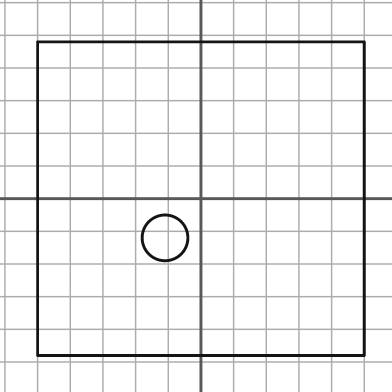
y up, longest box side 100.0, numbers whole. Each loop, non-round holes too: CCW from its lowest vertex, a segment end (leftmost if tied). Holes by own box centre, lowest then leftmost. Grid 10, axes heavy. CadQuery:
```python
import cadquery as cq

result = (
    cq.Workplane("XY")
    .moveTo(-50.0, -48.0)
    .lineTo(50.0, -48.0)
    .lineTo(50.0, 48.0)
    .lineTo(-50.0, 48.0)
    .close()
    .moveTo(-11.0, -12.0)
    .circle(7.0)
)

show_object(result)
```